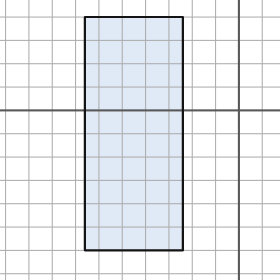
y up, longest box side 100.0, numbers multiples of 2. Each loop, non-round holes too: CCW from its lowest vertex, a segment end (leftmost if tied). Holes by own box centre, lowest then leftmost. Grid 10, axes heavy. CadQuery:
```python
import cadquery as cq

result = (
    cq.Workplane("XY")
    .moveTo(-66.0, -60.0)
    .lineTo(-24.0, -60.0)
    .lineTo(-24.0, 40.0)
    .lineTo(-66.0, 40.0)
    .close()
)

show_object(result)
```